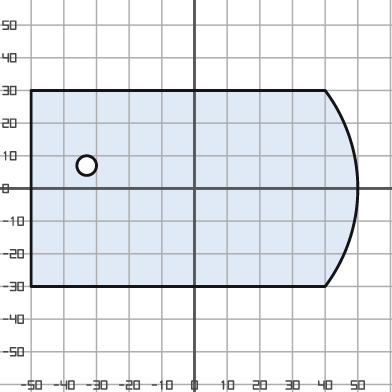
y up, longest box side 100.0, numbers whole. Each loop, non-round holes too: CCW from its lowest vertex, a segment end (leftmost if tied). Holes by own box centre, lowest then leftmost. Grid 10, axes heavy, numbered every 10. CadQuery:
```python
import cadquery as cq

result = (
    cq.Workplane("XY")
    .moveTo(-50.0, -30.0)
    .lineTo(40.0, -30.0)
    .threePointArc((50.0, 0.0), (40.0, 30.0))
    .lineTo(-50.0, 30.0)
    .close()
    .moveTo(-33.0, 7.0)
    .circle(3.0)
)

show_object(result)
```